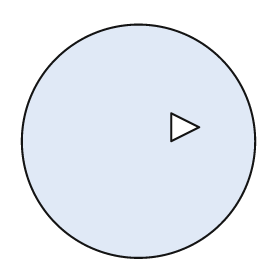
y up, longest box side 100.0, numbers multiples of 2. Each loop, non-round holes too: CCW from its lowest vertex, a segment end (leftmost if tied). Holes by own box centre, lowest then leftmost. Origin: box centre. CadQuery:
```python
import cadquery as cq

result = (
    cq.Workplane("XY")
    .moveTo(0.0, 0.0)
    .circle(50.0)
    .moveTo(14.0, 0.0)
    .lineTo(26.0, 6.0)
    .lineTo(14.0, 12.0)
    .close()
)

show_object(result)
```